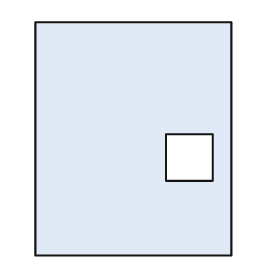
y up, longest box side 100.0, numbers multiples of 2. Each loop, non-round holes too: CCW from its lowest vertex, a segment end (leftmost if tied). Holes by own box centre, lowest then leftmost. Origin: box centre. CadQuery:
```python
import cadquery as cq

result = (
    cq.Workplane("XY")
    .moveTo(-42.0, -50.0)
    .lineTo(42.0, -50.0)
    .lineTo(42.0, 50.0)
    .lineTo(-42.0, 50.0)
    .close()
    .moveTo(14.0, -18.0)
    .lineTo(34.0, -18.0)
    .lineTo(34.0, 2.0)
    .lineTo(14.0, 2.0)
    .close()
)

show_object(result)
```